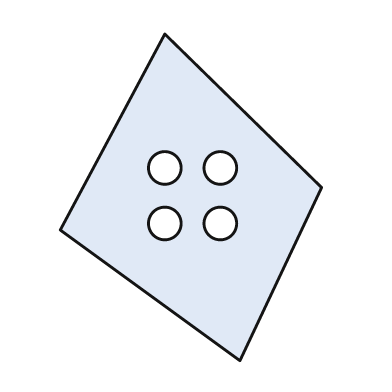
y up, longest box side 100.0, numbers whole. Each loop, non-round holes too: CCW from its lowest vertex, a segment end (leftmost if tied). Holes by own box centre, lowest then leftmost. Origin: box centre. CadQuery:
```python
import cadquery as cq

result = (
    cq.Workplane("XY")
    .moveTo(15.0, -50.0)
    .lineTo(40.0, 3.0)
    .lineTo(-8.0, 50.0)
    .lineTo(-40.0, -10.0)
    .close()
    .moveTo(-8.0, -8.0)
    .circle(5.0)
    .moveTo(9.0, -8.0)
    .circle(5.0)
    .moveTo(-8.0, 9.0)
    .circle(5.0)
    .moveTo(9.0, 9.0)
    .circle(5.0)
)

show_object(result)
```